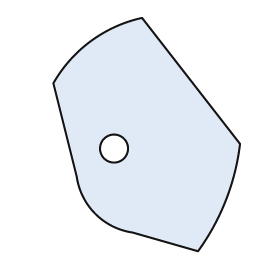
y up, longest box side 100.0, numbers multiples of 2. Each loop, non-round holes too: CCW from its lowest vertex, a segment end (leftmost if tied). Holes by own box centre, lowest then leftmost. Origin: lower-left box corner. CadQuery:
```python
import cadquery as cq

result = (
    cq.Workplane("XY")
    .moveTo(62.0, 0.0)
    .threePointArc((74.0, 22.0), (80.0, 46.0))
    .lineTo(38.0, 100.0)
    .threePointArc((16.0, 90.0), (0.0, 72.0))
    .lineTo(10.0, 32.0)
    .threePointArc((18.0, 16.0), (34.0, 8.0))
    .close()
    .moveTo(26.0, 44.0)
    .circle(6.0)
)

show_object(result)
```